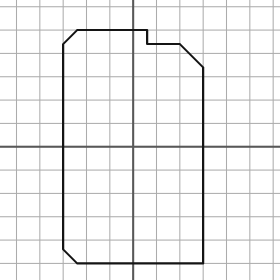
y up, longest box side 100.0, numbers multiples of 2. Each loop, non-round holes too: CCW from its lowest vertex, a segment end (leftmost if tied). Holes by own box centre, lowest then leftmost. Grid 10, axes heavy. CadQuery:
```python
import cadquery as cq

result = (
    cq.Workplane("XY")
    .moveTo(-24.0, -50.0)
    .lineTo(30.0, -50.0)
    .lineTo(30.0, 34.0)
    .lineTo(20.0, 44.0)
    .lineTo(6.0, 44.0)
    .lineTo(6.0, 50.0)
    .lineTo(-24.0, 50.0)
    .lineTo(-30.0, 44.0)
    .lineTo(-30.0, -44.0)
    .close()
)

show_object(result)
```